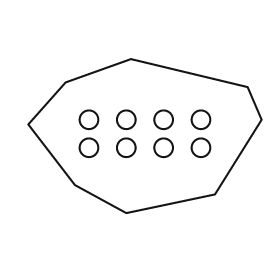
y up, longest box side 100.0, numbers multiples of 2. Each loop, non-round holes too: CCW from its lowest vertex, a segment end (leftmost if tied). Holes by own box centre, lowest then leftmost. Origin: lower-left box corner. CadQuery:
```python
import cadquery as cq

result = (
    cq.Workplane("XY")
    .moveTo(42.0, 0.0)
    .lineTo(80.0, 8.0)
    .lineTo(100.0, 40.0)
    .lineTo(94.0, 54.0)
    .lineTo(44.0, 66.0)
    .lineTo(16.0, 56.0)
    .lineTo(0.0, 38.0)
    .lineTo(20.0, 12.0)
    .close()
    .moveTo(26.0, 28.0)
    .circle(4.0)
    .moveTo(42.0, 28.0)
    .circle(4.0)
    .moveTo(58.0, 28.0)
    .circle(4.0)
    .moveTo(74.0, 28.0)
    .circle(4.0)
    .moveTo(26.0, 40.0)
    .circle(4.0)
    .moveTo(42.0, 40.0)
    .circle(4.0)
    .moveTo(58.0, 40.0)
    .circle(4.0)
    .moveTo(74.0, 40.0)
    .circle(4.0)
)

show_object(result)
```